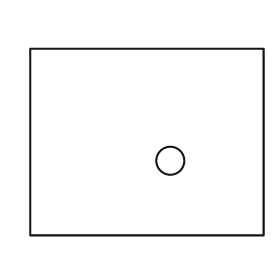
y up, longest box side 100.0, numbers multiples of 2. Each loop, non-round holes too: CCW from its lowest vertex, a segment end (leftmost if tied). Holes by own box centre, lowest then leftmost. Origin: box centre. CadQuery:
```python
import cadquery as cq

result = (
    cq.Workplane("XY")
    .moveTo(-50.0, -40.0)
    .lineTo(50.0, -40.0)
    .lineTo(50.0, 40.0)
    .lineTo(-50.0, 40.0)
    .close()
    .moveTo(10.0, -8.0)
    .circle(6.0)
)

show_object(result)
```